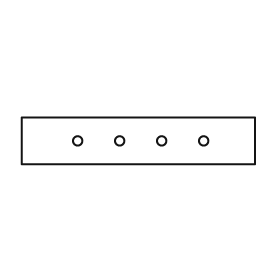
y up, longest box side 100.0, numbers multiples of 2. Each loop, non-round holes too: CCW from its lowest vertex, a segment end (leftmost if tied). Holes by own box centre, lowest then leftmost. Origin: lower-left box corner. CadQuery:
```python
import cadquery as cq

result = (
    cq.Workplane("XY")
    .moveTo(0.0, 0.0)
    .lineTo(100.0, 0.0)
    .lineTo(100.0, 20.0)
    .lineTo(0.0, 20.0)
    .close()
    .moveTo(24.0, 10.0)
    .circle(2.0)
    .moveTo(42.0, 10.0)
    .circle(2.0)
    .moveTo(60.0, 10.0)
    .circle(2.0)
    .moveTo(78.0, 10.0)
    .circle(2.0)
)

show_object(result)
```